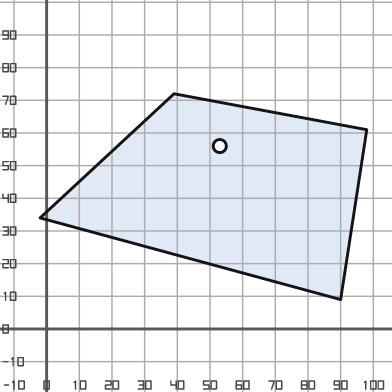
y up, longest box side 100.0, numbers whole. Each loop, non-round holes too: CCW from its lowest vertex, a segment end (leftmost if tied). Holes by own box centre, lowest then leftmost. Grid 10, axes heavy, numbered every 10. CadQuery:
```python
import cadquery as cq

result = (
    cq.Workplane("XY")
    .moveTo(90.0, 9.0)
    .lineTo(98.0, 61.0)
    .lineTo(39.0, 72.0)
    .lineTo(-2.0, 34.0)
    .close()
    .moveTo(53.0, 56.0)
    .circle(2.0)
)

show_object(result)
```